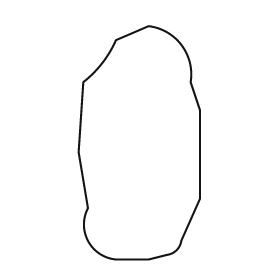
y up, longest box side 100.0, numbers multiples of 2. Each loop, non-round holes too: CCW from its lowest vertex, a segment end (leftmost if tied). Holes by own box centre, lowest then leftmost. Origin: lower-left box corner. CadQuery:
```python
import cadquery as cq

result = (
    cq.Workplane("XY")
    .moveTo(16.0, 0.0)
    .lineTo(30.0, 0.0)
    .lineTo(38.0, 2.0)
    .threePointArc((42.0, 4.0), (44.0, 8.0))
    .lineTo(52.0, 26.0)
    .lineTo(52.0, 64.0)
    .lineTo(48.0, 76.0)
    .threePointArc((44.0, 92.0), (30.0, 100.0))
    .lineTo(16.0, 94.0)
    .threePointArc((10.0, 84.0), (2.0, 76.0))
    .lineTo(0.0, 46.0)
    .lineTo(4.0, 22.0)
    .threePointArc((4.0, 8.0), (16.0, 0.0))
    .close()
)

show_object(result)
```